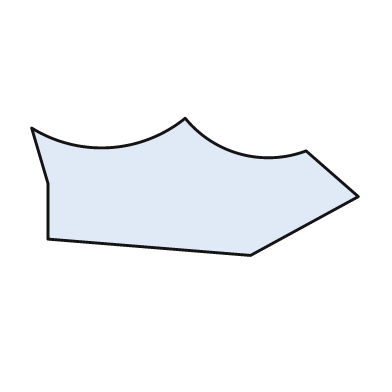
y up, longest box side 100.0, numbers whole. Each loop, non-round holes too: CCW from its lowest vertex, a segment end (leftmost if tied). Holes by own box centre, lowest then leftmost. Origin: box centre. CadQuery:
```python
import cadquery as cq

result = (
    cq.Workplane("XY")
    .moveTo(17.0, -21.0)
    .lineTo(50.0, -3.0)
    .lineTo(34.0, 11.0)
    .threePointArc((14.0, 10.0), (-3.0, 21.0))
    .threePointArc((-26.0, 12.0), (-50.0, 18.0))
    .lineTo(-45.0, 1.0)
    .lineTo(-45.0, -16.0)
    .close()
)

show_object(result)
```